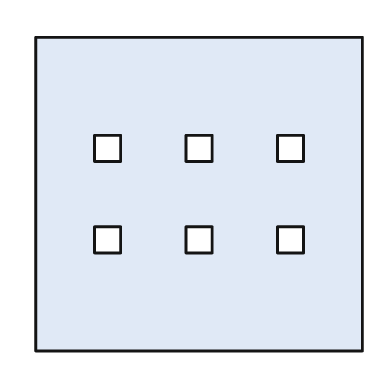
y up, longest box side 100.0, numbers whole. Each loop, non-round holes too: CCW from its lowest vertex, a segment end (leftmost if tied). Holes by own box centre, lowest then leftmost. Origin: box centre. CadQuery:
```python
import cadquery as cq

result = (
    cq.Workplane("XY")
    .moveTo(-50.0, -48.0)
    .lineTo(50.0, -48.0)
    .lineTo(50.0, 48.0)
    .lineTo(-50.0, 48.0)
    .close()
    .moveTo(-32.0, -18.0)
    .lineTo(-24.0, -18.0)
    .lineTo(-24.0, -10.0)
    .lineTo(-32.0, -10.0)
    .close()
    .moveTo(-4.0, -18.0)
    .lineTo(4.0, -18.0)
    .lineTo(4.0, -10.0)
    .lineTo(-4.0, -10.0)
    .close()
    .moveTo(24.0, -18.0)
    .lineTo(32.0, -18.0)
    .lineTo(32.0, -10.0)
    .lineTo(24.0, -10.0)
    .close()
    .moveTo(-32.0, 10.0)
    .lineTo(-24.0, 10.0)
    .lineTo(-24.0, 18.0)
    .lineTo(-32.0, 18.0)
    .close()
    .moveTo(-4.0, 10.0)
    .lineTo(4.0, 10.0)
    .lineTo(4.0, 18.0)
    .lineTo(-4.0, 18.0)
    .close()
    .moveTo(24.0, 10.0)
    .lineTo(32.0, 10.0)
    .lineTo(32.0, 18.0)
    .lineTo(24.0, 18.0)
    .close()
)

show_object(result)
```